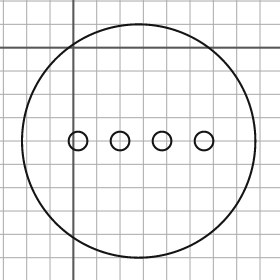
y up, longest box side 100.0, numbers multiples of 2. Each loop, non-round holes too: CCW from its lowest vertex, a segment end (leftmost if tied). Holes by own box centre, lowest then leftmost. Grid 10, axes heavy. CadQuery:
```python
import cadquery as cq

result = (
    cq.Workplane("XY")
    .moveTo(28.0, -40.0)
    .circle(50.0)
    .moveTo(2.0, -40.0)
    .circle(4.0)
    .moveTo(20.0, -40.0)
    .circle(4.0)
    .moveTo(38.0, -40.0)
    .circle(4.0)
    .moveTo(56.0, -40.0)
    .circle(4.0)
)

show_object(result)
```